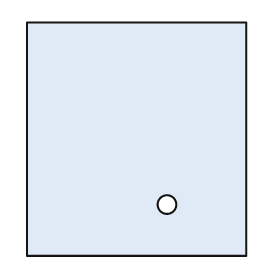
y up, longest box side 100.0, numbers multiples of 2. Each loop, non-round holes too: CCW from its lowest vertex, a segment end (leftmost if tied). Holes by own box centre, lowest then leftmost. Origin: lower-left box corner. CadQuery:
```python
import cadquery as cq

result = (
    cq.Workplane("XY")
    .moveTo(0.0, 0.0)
    .lineTo(94.0, 0.0)
    .lineTo(94.0, 100.0)
    .lineTo(0.0, 100.0)
    .close()
    .moveTo(60.0, 22.0)
    .circle(4.0)
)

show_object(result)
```